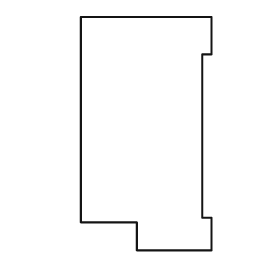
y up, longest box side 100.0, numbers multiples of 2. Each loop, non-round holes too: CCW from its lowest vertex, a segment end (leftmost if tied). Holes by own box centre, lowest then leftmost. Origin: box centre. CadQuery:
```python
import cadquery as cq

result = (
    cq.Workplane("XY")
    .moveTo(-4.0, -50.0)
    .lineTo(28.0, -50.0)
    .lineTo(28.0, -36.0)
    .lineTo(24.0, -36.0)
    .lineTo(24.0, 34.0)
    .lineTo(28.0, 34.0)
    .lineTo(28.0, 50.0)
    .lineTo(-28.0, 50.0)
    .lineTo(-28.0, -38.0)
    .lineTo(-4.0, -38.0)
    .close()
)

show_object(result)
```